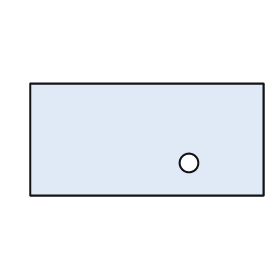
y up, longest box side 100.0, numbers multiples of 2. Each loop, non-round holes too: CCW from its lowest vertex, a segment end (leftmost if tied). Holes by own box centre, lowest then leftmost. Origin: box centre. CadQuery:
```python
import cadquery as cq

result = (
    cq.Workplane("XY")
    .moveTo(-50.0, -24.0)
    .lineTo(50.0, -24.0)
    .lineTo(50.0, 24.0)
    .lineTo(-50.0, 24.0)
    .close()
    .moveTo(18.0, -10.0)
    .circle(4.0)
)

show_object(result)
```